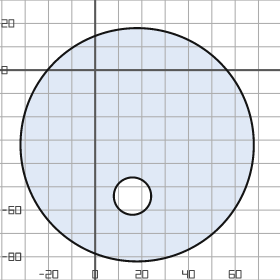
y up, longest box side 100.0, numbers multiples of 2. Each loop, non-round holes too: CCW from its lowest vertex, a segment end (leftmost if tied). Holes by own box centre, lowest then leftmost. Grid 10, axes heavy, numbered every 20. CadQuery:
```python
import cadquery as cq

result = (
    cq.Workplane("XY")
    .moveTo(18.0, -32.0)
    .circle(50.0)
    .moveTo(16.0, -54.0)
    .circle(8.0)
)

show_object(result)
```